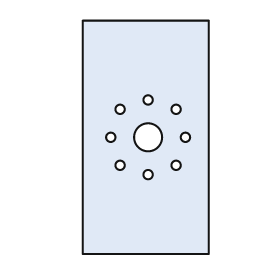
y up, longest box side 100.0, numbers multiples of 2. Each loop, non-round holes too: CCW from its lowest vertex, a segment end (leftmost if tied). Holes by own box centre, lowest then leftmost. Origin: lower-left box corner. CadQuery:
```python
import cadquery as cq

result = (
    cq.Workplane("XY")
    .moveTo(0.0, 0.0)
    .lineTo(54.0, 0.0)
    .lineTo(54.0, 100.0)
    .lineTo(0.0, 100.0)
    .close()
    .moveTo(28.0, 34.0)
    .circle(2.0)
    .moveTo(16.0, 38.0)
    .circle(2.0)
    .moveTo(40.0, 38.0)
    .circle(2.0)
    .moveTo(12.0, 50.0)
    .circle(2.0)
    .moveTo(28.0, 50.0)
    .circle(6.0)
    .moveTo(44.0, 50.0)
    .circle(2.0)
    .moveTo(16.0, 62.0)
    .circle(2.0)
    .moveTo(40.0, 62.0)
    .circle(2.0)
    .moveTo(28.0, 66.0)
    .circle(2.0)
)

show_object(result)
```